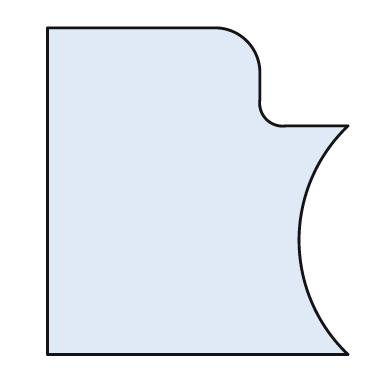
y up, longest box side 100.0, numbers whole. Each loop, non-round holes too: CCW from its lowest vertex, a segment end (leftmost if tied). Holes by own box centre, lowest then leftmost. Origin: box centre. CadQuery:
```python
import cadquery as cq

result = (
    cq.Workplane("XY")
    .moveTo(-46.0, -50.0)
    .lineTo(46.0, -50.0)
    .threePointArc((31.0, -15.0), (46.0, 20.0))
    .lineTo(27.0, 20.0)
    .threePointArc((21.0, 22.0), (19.0, 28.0))
    .lineTo(19.0, 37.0)
    .threePointArc((15.0, 46.0), (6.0, 50.0))
    .lineTo(-46.0, 50.0)
    .close()
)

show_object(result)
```